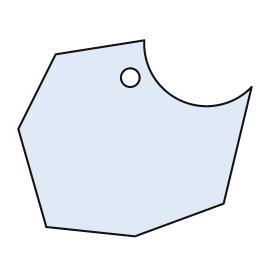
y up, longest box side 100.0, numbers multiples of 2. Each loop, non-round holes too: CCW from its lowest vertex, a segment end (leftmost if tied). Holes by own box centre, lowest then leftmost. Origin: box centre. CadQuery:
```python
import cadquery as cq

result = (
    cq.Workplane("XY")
    .moveTo(0.0, -42.0)
    .lineTo(38.0, -28.0)
    .lineTo(50.0, 22.0)
    .threePointArc((20.0, 16.0), (4.0, 42.0))
    .lineTo(-34.0, 36.0)
    .lineTo(-50.0, 4.0)
    .lineTo(-38.0, -38.0)
    .close()
    .moveTo(-2.0, 26.0)
    .circle(4.0)
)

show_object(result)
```